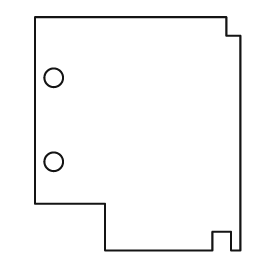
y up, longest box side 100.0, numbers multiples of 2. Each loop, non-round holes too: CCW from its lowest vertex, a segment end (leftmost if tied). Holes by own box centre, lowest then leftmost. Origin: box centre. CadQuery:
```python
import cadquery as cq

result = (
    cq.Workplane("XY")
    .moveTo(-14.0, -50.0)
    .lineTo(32.0, -50.0)
    .lineTo(32.0, -42.0)
    .lineTo(40.0, -42.0)
    .lineTo(40.0, -50.0)
    .lineTo(44.0, -50.0)
    .lineTo(44.0, 42.0)
    .lineTo(38.0, 42.0)
    .lineTo(38.0, 50.0)
    .lineTo(-44.0, 50.0)
    .lineTo(-44.0, -30.0)
    .lineTo(-14.0, -30.0)
    .close()
    .moveTo(-36.0, -12.0)
    .circle(4.0)
    .moveTo(-36.0, 24.0)
    .circle(4.0)
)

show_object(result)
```